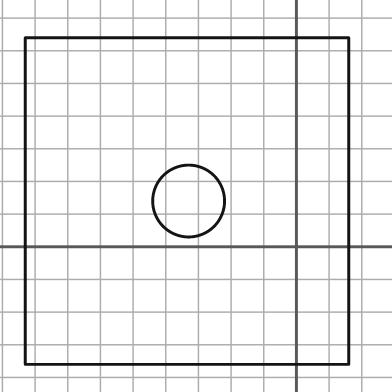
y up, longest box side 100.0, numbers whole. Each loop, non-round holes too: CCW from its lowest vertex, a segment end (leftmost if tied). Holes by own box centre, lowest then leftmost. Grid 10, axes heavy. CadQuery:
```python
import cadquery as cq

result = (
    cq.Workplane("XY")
    .moveTo(-83.0, -36.0)
    .lineTo(16.0, -36.0)
    .lineTo(16.0, 64.0)
    .lineTo(-83.0, 64.0)
    .close()
    .moveTo(-33.0, 14.0)
    .circle(11.0)
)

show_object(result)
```